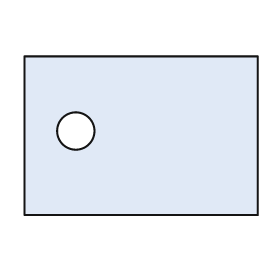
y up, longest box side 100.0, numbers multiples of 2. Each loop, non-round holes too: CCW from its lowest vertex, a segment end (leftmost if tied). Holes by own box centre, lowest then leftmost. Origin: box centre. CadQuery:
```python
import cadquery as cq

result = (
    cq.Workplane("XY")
    .moveTo(-50.0, -34.0)
    .lineTo(50.0, -34.0)
    .lineTo(50.0, 34.0)
    .lineTo(-50.0, 34.0)
    .close()
    .moveTo(-28.0, 2.0)
    .circle(8.0)
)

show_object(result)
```